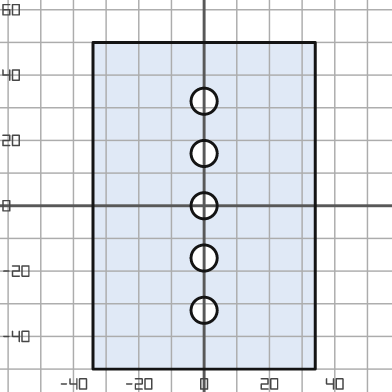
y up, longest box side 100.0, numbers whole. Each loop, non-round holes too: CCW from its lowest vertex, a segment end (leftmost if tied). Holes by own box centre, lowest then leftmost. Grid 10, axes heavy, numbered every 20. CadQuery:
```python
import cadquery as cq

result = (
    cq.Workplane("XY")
    .moveTo(-34.0, -50.0)
    .lineTo(34.0, -50.0)
    .lineTo(34.0, 50.0)
    .lineTo(-34.0, 50.0)
    .close()
    .moveTo(0.0, -32.0)
    .circle(4.0)
    .moveTo(0.0, -16.0)
    .circle(4.0)
    .moveTo(0.0, 0.0)
    .circle(4.0)
    .moveTo(0.0, 16.0)
    .circle(4.0)
    .moveTo(0.0, 32.0)
    .circle(4.0)
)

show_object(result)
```